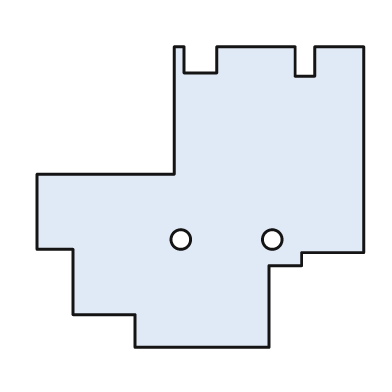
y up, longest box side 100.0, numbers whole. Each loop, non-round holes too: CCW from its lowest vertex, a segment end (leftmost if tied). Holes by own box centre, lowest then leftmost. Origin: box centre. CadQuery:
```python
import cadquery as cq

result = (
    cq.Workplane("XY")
    .moveTo(-20.0, -46.0)
    .lineTo(21.0, -46.0)
    .lineTo(21.0, -21.0)
    .lineTo(31.0, -21.0)
    .lineTo(31.0, -17.0)
    .lineTo(50.0, -17.0)
    .lineTo(50.0, 46.0)
    .lineTo(35.0, 46.0)
    .lineTo(35.0, 37.0)
    .lineTo(29.0, 37.0)
    .lineTo(29.0, 46.0)
    .lineTo(5.0, 46.0)
    .lineTo(5.0, 38.0)
    .lineTo(-5.0, 38.0)
    .lineTo(-5.0, 46.0)
    .lineTo(-8.0, 46.0)
    .lineTo(-8.0, 7.0)
    .lineTo(-50.0, 7.0)
    .lineTo(-50.0, -16.0)
    .lineTo(-39.0, -16.0)
    .lineTo(-39.0, -36.0)
    .lineTo(-20.0, -36.0)
    .close()
    .moveTo(-6.0, -13.0)
    .circle(3.0)
    .moveTo(22.0, -13.0)
    .circle(3.0)
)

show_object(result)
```